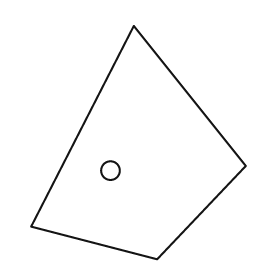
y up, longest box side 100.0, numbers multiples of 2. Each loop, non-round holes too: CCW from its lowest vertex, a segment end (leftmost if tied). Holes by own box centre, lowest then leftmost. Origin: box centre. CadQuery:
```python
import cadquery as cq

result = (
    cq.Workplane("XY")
    .moveTo(8.0, -50.0)
    .lineTo(46.0, -10.0)
    .lineTo(-2.0, 50.0)
    .lineTo(-46.0, -36.0)
    .close()
    .moveTo(-12.0, -12.0)
    .circle(4.0)
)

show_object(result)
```